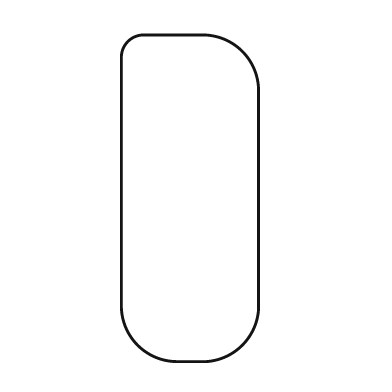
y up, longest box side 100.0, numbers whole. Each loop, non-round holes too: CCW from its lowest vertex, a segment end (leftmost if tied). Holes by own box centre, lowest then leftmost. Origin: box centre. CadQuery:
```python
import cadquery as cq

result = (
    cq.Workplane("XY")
    .moveTo(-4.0, -50.0)
    .lineTo(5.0, -50.0)
    .threePointArc((16.0, -45.0), (21.0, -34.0))
    .lineTo(21.0, 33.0)
    .threePointArc((16.0, 45.0), (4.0, 50.0))
    .lineTo(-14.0, 50.0)
    .threePointArc((-19.0, 48.0), (-21.0, 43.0))
    .lineTo(-21.0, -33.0)
    .threePointArc((-16.0, -45.0), (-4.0, -50.0))
    .close()
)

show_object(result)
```